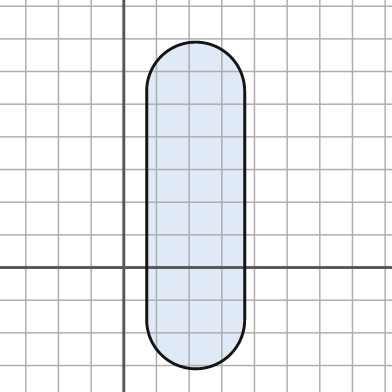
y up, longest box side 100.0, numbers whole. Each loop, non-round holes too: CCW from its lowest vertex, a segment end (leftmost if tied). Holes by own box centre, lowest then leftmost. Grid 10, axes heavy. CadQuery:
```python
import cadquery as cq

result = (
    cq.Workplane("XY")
    .moveTo(7.0, -16.0)
    .threePointArc((22.0, -31.0), (37.0, -16.0))
    .lineTo(37.0, 54.0)
    .threePointArc((22.0, 69.0), (7.0, 54.0))
    .close()
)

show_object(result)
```